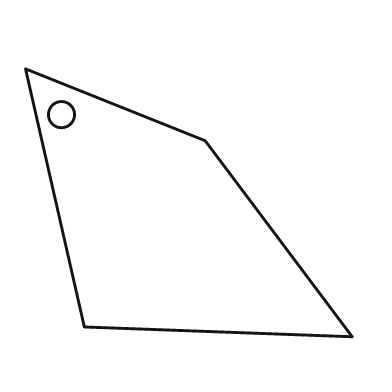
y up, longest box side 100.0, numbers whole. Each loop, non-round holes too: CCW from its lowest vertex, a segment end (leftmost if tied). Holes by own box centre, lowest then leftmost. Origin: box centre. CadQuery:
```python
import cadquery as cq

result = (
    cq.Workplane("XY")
    .moveTo(50.0, -41.0)
    .lineTo(5.0, 19.0)
    .lineTo(-50.0, 41.0)
    .lineTo(-32.0, -38.0)
    .close()
    .moveTo(-39.0, 27.0)
    .circle(4.0)
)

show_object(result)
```